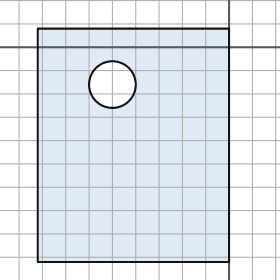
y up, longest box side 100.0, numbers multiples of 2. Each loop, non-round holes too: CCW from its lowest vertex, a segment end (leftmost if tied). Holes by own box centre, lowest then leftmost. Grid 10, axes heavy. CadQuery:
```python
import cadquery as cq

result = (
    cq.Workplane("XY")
    .moveTo(-82.0, -92.0)
    .lineTo(0.0, -92.0)
    .lineTo(0.0, 8.0)
    .lineTo(-82.0, 8.0)
    .close()
    .moveTo(-50.0, -16.0)
    .circle(10.0)
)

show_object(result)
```